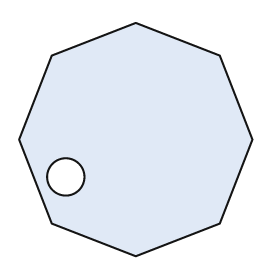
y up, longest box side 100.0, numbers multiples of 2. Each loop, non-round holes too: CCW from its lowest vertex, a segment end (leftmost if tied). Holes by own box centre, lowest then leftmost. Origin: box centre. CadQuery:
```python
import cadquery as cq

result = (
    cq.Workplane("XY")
    .moveTo(0.0, -50.0)
    .lineTo(36.0, -36.0)
    .lineTo(50.0, 0.0)
    .lineTo(36.0, 36.0)
    .lineTo(0.0, 50.0)
    .lineTo(-36.0, 36.0)
    .lineTo(-50.0, 0.0)
    .lineTo(-36.0, -36.0)
    .close()
    .moveTo(-30.0, -16.0)
    .circle(8.0)
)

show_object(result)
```